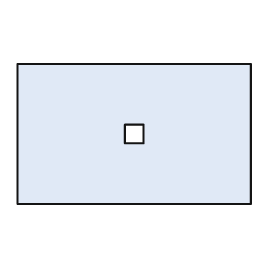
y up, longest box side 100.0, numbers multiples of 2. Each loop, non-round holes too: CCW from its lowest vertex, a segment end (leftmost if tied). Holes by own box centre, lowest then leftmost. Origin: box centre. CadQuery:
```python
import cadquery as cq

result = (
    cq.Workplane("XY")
    .moveTo(-50.0, -30.0)
    .lineTo(50.0, -30.0)
    .lineTo(50.0, 30.0)
    .lineTo(-50.0, 30.0)
    .close()
    .moveTo(-4.0, -4.0)
    .lineTo(4.0, -4.0)
    .lineTo(4.0, 4.0)
    .lineTo(-4.0, 4.0)
    .close()
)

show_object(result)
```